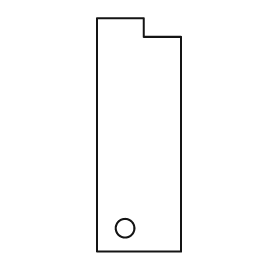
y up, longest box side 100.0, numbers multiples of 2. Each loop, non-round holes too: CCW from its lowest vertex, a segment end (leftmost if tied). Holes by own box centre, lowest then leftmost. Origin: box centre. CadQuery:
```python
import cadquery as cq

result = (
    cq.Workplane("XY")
    .moveTo(-18.0, -50.0)
    .lineTo(18.0, -50.0)
    .lineTo(18.0, 42.0)
    .lineTo(2.0, 42.0)
    .lineTo(2.0, 50.0)
    .lineTo(-18.0, 50.0)
    .close()
    .moveTo(-6.0, -40.0)
    .circle(4.0)
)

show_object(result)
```